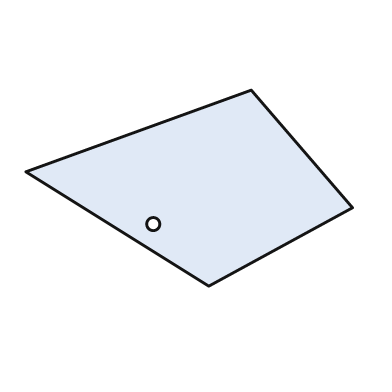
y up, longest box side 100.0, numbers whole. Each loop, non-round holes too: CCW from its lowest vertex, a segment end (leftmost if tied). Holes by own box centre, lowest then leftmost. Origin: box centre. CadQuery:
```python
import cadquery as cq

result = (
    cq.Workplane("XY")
    .moveTo(6.0, -30.0)
    .lineTo(50.0, -6.0)
    .lineTo(19.0, 30.0)
    .lineTo(-50.0, 5.0)
    .close()
    .moveTo(-11.0, -11.0)
    .circle(2.0)
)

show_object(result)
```